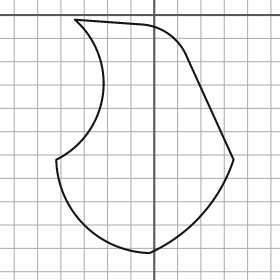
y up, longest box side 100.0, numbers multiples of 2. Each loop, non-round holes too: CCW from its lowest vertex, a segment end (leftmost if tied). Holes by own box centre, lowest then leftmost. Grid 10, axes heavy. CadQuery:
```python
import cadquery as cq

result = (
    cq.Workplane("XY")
    .moveTo(-2.0, -102.0)
    .threePointArc((20.0, -86.0), (34.0, -62.0))
    .lineTo(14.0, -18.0)
    .threePointArc((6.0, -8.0), (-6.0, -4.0))
    .lineTo(-34.0, -2.0)
    .threePointArc((-22.0, -34.0), (-42.0, -62.0))
    .threePointArc((-30.0, -90.0), (-2.0, -102.0))
    .close()
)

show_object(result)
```